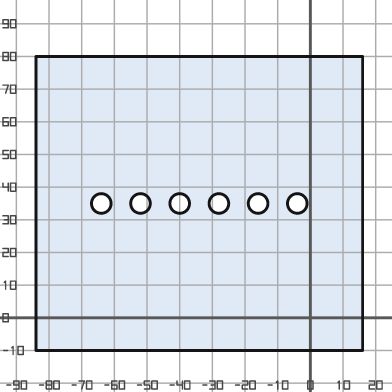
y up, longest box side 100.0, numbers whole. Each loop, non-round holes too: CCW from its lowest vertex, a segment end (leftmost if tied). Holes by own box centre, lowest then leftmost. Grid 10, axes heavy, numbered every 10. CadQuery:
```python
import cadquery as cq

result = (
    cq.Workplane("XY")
    .moveTo(-84.0, -10.0)
    .lineTo(16.0, -10.0)
    .lineTo(16.0, 80.0)
    .lineTo(-84.0, 80.0)
    .close()
    .moveTo(-64.0, 35.0)
    .circle(3.0)
    .moveTo(-52.0, 35.0)
    .circle(3.0)
    .moveTo(-40.0, 35.0)
    .circle(3.0)
    .moveTo(-28.0, 35.0)
    .circle(3.0)
    .moveTo(-16.0, 35.0)
    .circle(3.0)
    .moveTo(-4.0, 35.0)
    .circle(3.0)
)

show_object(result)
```